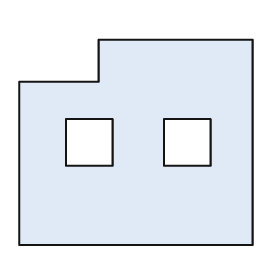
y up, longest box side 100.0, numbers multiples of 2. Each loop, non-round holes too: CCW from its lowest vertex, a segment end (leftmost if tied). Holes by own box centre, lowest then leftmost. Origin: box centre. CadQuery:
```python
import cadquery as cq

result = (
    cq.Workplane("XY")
    .moveTo(-50.0, -44.0)
    .lineTo(50.0, -44.0)
    .lineTo(50.0, 44.0)
    .lineTo(-16.0, 44.0)
    .lineTo(-16.0, 26.0)
    .lineTo(-50.0, 26.0)
    .close()
    .moveTo(-30.0, -10.0)
    .lineTo(-10.0, -10.0)
    .lineTo(-10.0, 10.0)
    .lineTo(-30.0, 10.0)
    .close()
    .moveTo(12.0, -10.0)
    .lineTo(32.0, -10.0)
    .lineTo(32.0, 10.0)
    .lineTo(12.0, 10.0)
    .close()
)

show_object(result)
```